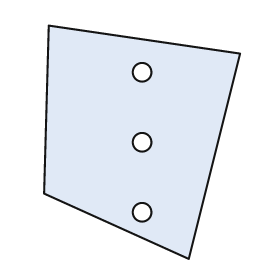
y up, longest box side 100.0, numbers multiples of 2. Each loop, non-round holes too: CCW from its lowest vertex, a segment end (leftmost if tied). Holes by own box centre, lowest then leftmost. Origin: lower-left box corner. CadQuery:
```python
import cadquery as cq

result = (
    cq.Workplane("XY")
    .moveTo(62.0, 0.0)
    .lineTo(84.0, 88.0)
    .lineTo(2.0, 100.0)
    .lineTo(0.0, 28.0)
    .close()
    .moveTo(42.0, 20.0)
    .circle(4.0)
    .moveTo(42.0, 50.0)
    .circle(4.0)
    .moveTo(42.0, 80.0)
    .circle(4.0)
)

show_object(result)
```